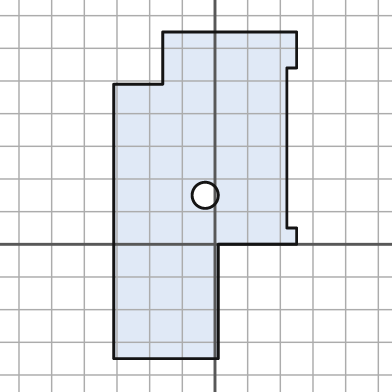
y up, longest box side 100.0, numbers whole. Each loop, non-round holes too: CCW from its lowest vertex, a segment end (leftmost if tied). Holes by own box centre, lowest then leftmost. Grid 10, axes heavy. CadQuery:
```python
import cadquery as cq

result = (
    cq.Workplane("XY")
    .moveTo(-31.0, -35.0)
    .lineTo(1.0, -35.0)
    .lineTo(1.0, 0.0)
    .lineTo(25.0, 0.0)
    .lineTo(25.0, 5.0)
    .lineTo(22.0, 5.0)
    .lineTo(22.0, 54.0)
    .lineTo(25.0, 54.0)
    .lineTo(25.0, 65.0)
    .lineTo(-16.0, 65.0)
    .lineTo(-16.0, 49.0)
    .lineTo(-31.0, 49.0)
    .close()
    .moveTo(-3.0, 15.0)
    .circle(4.0)
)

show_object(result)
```